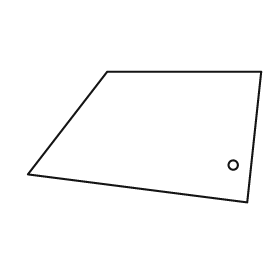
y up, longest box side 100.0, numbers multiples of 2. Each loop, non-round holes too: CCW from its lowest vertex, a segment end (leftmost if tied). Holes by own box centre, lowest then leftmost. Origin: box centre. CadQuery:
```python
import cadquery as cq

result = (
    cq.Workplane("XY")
    .moveTo(44.0, -28.0)
    .lineTo(50.0, 28.0)
    .lineTo(-16.0, 28.0)
    .lineTo(-50.0, -16.0)
    .close()
    .moveTo(38.0, -12.0)
    .circle(2.0)
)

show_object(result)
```